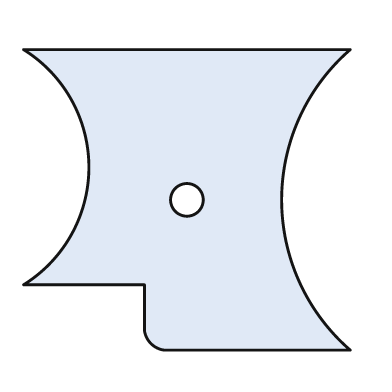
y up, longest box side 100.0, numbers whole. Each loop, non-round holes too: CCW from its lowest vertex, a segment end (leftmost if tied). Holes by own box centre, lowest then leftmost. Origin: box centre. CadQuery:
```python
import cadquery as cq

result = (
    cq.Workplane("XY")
    .moveTo(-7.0, -46.0)
    .lineTo(50.0, -46.0)
    .threePointArc((29.0, 0.0), (50.0, 46.0))
    .lineTo(-50.0, 46.0)
    .threePointArc((-30.0, 10.0), (-50.0, -26.0))
    .lineTo(-13.0, -26.0)
    .lineTo(-13.0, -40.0)
    .threePointArc((-11.0, -44.0), (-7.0, -46.0))
    .close()
    .moveTo(0.0, 0.0)
    .circle(5.0)
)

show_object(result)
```